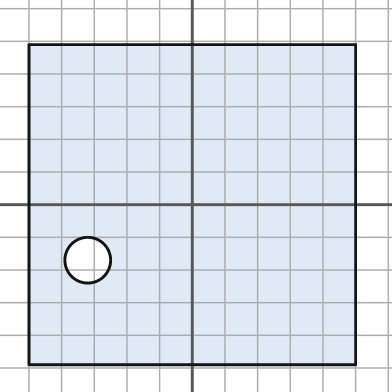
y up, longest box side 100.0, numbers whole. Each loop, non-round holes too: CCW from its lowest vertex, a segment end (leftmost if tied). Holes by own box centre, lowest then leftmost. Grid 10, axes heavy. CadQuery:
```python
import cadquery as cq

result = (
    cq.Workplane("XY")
    .moveTo(-50.0, -49.0)
    .lineTo(50.0, -49.0)
    .lineTo(50.0, 49.0)
    .lineTo(-50.0, 49.0)
    .close()
    .moveTo(-32.0, -17.0)
    .circle(7.0)
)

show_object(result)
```